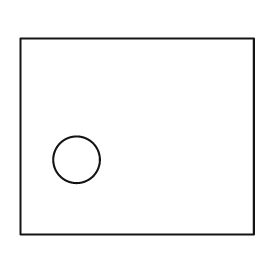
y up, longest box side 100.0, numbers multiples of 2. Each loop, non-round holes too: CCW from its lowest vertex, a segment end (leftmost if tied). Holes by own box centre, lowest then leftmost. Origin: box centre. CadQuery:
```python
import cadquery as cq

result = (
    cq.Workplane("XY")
    .moveTo(-50.0, -42.0)
    .lineTo(50.0, -42.0)
    .lineTo(50.0, 42.0)
    .lineTo(-50.0, 42.0)
    .close()
    .moveTo(-26.0, -10.0)
    .circle(10.0)
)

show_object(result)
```